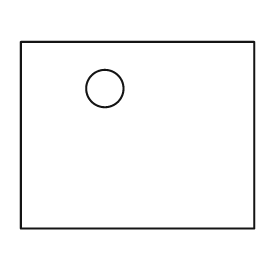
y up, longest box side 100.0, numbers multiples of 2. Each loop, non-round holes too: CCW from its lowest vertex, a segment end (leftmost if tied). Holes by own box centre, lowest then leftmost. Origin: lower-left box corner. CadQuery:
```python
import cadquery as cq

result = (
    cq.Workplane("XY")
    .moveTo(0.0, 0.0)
    .lineTo(100.0, 0.0)
    .lineTo(100.0, 80.0)
    .lineTo(0.0, 80.0)
    .close()
    .moveTo(36.0, 60.0)
    .circle(8.0)
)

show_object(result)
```